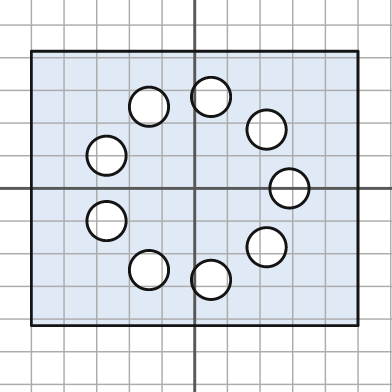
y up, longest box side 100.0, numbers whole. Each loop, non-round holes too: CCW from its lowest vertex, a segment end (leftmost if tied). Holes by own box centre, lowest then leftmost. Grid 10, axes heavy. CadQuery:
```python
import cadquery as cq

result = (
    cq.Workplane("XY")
    .moveTo(-50.0, -42.0)
    .lineTo(50.0, -42.0)
    .lineTo(50.0, 42.0)
    .lineTo(-50.0, 42.0)
    .close()
    .moveTo(5.0, -28.0)
    .circle(6.0)
    .moveTo(-14.0, -25.0)
    .circle(6.0)
    .moveTo(22.0, -18.0)
    .circle(6.0)
    .moveTo(-27.0, -10.0)
    .circle(6.0)
    .moveTo(29.0, 0.0)
    .circle(6.0)
    .moveTo(-27.0, 10.0)
    .circle(6.0)
    .moveTo(22.0, 18.0)
    .circle(6.0)
    .moveTo(-14.0, 25.0)
    .circle(6.0)
    .moveTo(5.0, 28.0)
    .circle(6.0)
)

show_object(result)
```